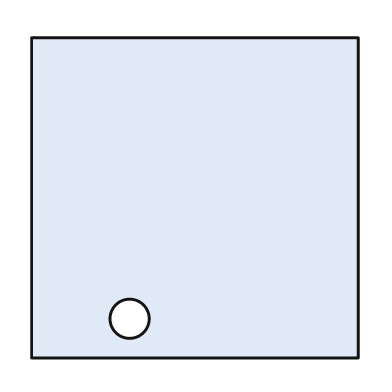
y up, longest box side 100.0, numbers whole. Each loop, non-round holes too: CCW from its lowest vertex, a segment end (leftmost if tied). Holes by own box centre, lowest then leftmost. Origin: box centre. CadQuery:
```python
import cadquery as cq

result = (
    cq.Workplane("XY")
    .moveTo(-50.0, -49.0)
    .lineTo(50.0, -49.0)
    .lineTo(50.0, 49.0)
    .lineTo(-50.0, 49.0)
    .close()
    .moveTo(-20.0, -37.0)
    .circle(6.0)
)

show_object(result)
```